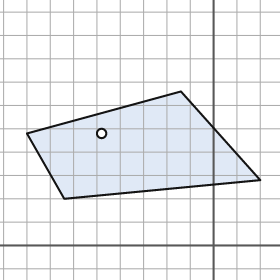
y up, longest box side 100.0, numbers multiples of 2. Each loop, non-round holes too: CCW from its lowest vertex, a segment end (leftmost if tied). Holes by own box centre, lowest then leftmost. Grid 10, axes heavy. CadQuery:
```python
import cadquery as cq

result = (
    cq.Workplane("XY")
    .moveTo(-64.0, 20.0)
    .lineTo(20.0, 28.0)
    .lineTo(-14.0, 66.0)
    .lineTo(-80.0, 48.0)
    .close()
    .moveTo(-48.0, 48.0)
    .circle(2.0)
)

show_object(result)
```